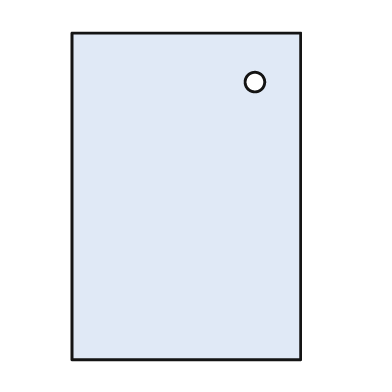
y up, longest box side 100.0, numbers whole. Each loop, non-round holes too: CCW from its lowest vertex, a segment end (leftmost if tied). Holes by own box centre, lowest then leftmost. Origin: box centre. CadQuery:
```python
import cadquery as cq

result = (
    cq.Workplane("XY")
    .moveTo(-35.0, -50.0)
    .lineTo(35.0, -50.0)
    .lineTo(35.0, 50.0)
    .lineTo(-35.0, 50.0)
    .close()
    .moveTo(21.0, 35.0)
    .circle(3.0)
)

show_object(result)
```